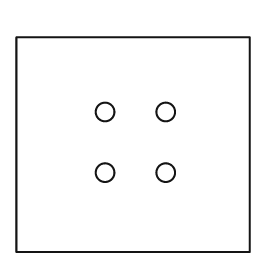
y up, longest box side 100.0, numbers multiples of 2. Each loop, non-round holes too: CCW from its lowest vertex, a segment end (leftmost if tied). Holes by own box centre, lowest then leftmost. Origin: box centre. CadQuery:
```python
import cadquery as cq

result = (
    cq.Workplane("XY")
    .moveTo(-50.0, -46.0)
    .lineTo(50.0, -46.0)
    .lineTo(50.0, 46.0)
    .lineTo(-50.0, 46.0)
    .close()
    .moveTo(-12.0, -12.0)
    .circle(4.0)
    .moveTo(14.0, -12.0)
    .circle(4.0)
    .moveTo(-12.0, 14.0)
    .circle(4.0)
    .moveTo(14.0, 14.0)
    .circle(4.0)
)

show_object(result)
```